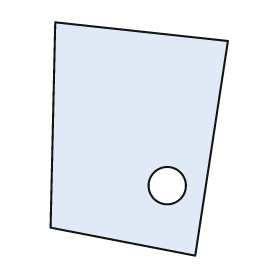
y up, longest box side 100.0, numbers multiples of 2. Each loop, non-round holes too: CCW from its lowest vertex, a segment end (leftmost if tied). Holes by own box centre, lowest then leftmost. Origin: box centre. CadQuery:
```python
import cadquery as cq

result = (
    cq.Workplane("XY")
    .moveTo(24.0, -50.0)
    .lineTo(38.0, 42.0)
    .lineTo(-36.0, 50.0)
    .lineTo(-38.0, -38.0)
    .close()
    .moveTo(12.0, -20.0)
    .circle(8.0)
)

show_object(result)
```